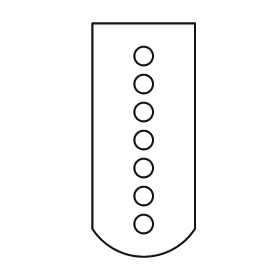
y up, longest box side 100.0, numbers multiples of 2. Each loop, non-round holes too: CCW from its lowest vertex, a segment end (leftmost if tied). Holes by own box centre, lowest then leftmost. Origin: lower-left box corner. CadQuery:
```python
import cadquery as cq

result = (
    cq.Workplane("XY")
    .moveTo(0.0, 12.0)
    .threePointArc((22.0, 0.0), (44.0, 12.0))
    .lineTo(44.0, 100.0)
    .lineTo(0.0, 100.0)
    .close()
    .moveTo(22.0, 14.0)
    .circle(4.0)
    .moveTo(22.0, 26.0)
    .circle(4.0)
    .moveTo(22.0, 38.0)
    .circle(4.0)
    .moveTo(22.0, 50.0)
    .circle(4.0)
    .moveTo(22.0, 62.0)
    .circle(4.0)
    .moveTo(22.0, 74.0)
    .circle(4.0)
    .moveTo(22.0, 86.0)
    .circle(4.0)
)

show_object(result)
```